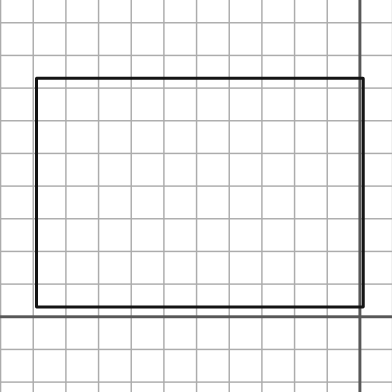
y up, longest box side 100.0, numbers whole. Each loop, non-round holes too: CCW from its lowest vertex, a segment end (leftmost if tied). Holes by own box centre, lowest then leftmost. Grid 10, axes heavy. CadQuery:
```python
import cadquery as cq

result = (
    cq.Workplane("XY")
    .moveTo(-99.0, 3.0)
    .lineTo(1.0, 3.0)
    .lineTo(1.0, 73.0)
    .lineTo(-99.0, 73.0)
    .close()
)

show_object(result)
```